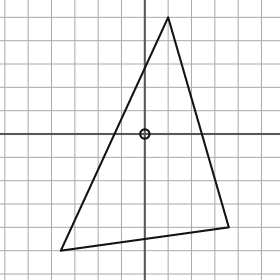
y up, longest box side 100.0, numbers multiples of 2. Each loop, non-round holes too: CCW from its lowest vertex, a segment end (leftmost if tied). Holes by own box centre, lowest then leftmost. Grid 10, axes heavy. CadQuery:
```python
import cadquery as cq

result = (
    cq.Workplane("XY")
    .moveTo(-36.0, -50.0)
    .lineTo(36.0, -40.0)
    .lineTo(10.0, 50.0)
    .close()
    .moveTo(0.0, 0.0)
    .circle(2.0)
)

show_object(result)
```